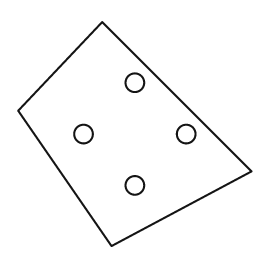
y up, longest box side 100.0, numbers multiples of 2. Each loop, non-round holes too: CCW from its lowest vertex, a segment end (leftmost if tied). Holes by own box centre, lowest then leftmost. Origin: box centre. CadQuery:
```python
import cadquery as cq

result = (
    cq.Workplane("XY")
    .moveTo(-10.0, -48.0)
    .lineTo(50.0, -16.0)
    .lineTo(-14.0, 48.0)
    .lineTo(-50.0, 10.0)
    .close()
    .moveTo(0.0, -22.0)
    .circle(4.0)
    .moveTo(-22.0, 0.0)
    .circle(4.0)
    .moveTo(22.0, 0.0)
    .circle(4.0)
    .moveTo(0.0, 22.0)
    .circle(4.0)
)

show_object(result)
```